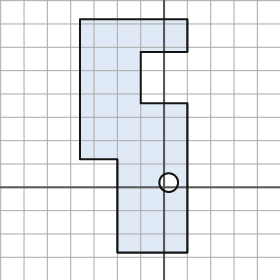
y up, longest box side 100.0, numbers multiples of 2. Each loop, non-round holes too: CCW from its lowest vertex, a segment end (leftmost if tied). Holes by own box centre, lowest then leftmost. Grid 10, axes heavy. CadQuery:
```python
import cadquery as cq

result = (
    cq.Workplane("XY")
    .moveTo(-20.0, -28.0)
    .lineTo(10.0, -28.0)
    .lineTo(10.0, 36.0)
    .lineTo(-10.0, 36.0)
    .lineTo(-10.0, 58.0)
    .lineTo(10.0, 58.0)
    .lineTo(10.0, 72.0)
    .lineTo(-36.0, 72.0)
    .lineTo(-36.0, 12.0)
    .lineTo(-20.0, 12.0)
    .close()
    .moveTo(2.0, 2.0)
    .circle(4.0)
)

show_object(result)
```